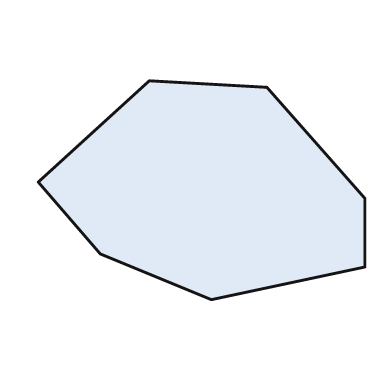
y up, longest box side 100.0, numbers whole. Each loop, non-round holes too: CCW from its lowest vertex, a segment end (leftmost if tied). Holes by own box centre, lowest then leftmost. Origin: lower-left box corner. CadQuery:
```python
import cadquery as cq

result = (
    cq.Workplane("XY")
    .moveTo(53.0, 0.0)
    .lineTo(100.0, 10.0)
    .lineTo(100.0, 31.0)
    .lineTo(70.0, 65.0)
    .lineTo(34.0, 67.0)
    .lineTo(0.0, 36.0)
    .lineTo(19.0, 14.0)
    .close()
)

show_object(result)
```